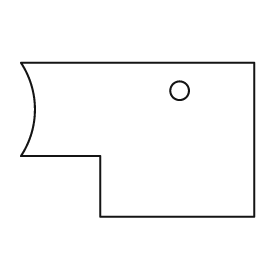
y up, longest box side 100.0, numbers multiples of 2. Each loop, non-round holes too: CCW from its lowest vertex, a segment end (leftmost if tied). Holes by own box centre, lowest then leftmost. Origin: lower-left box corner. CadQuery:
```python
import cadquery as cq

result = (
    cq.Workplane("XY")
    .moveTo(34.0, 0.0)
    .lineTo(100.0, 0.0)
    .lineTo(100.0, 66.0)
    .lineTo(0.0, 66.0)
    .threePointArc((6.0, 46.0), (0.0, 26.0))
    .lineTo(34.0, 26.0)
    .close()
    .moveTo(68.0, 54.0)
    .circle(4.0)
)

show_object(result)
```